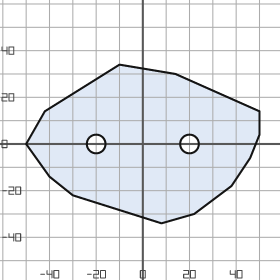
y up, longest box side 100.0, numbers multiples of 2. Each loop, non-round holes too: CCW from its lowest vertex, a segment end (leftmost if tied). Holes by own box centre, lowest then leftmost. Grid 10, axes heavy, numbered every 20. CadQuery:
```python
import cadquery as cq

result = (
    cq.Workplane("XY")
    .moveTo(8.0, -34.0)
    .lineTo(22.0, -30.0)
    .lineTo(38.0, -18.0)
    .lineTo(46.0, -6.0)
    .lineTo(50.0, 4.0)
    .lineTo(50.0, 14.0)
    .lineTo(14.0, 30.0)
    .lineTo(-10.0, 34.0)
    .lineTo(-42.0, 14.0)
    .lineTo(-50.0, 0.0)
    .lineTo(-40.0, -14.0)
    .lineTo(-30.0, -22.0)
    .close()
    .moveTo(-20.0, 0.0)
    .circle(4.0)
    .moveTo(20.0, 0.0)
    .circle(4.0)
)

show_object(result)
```